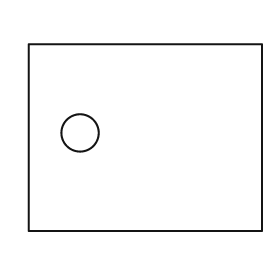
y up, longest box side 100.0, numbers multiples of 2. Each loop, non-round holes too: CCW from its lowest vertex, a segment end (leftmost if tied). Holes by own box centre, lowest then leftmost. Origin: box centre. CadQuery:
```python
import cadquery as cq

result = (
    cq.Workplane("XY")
    .moveTo(-50.0, -40.0)
    .lineTo(50.0, -40.0)
    .lineTo(50.0, 40.0)
    .lineTo(-50.0, 40.0)
    .close()
    .moveTo(-28.0, 2.0)
    .circle(8.0)
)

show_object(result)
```